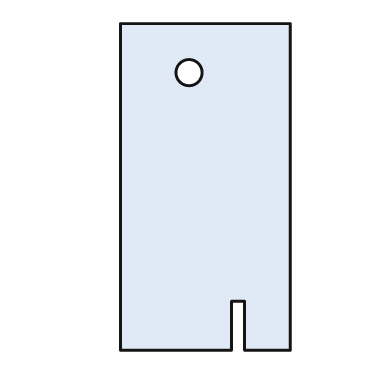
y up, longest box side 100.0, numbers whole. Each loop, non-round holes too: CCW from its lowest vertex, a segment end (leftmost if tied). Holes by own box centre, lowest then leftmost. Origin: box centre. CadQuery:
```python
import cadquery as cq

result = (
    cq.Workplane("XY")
    .moveTo(-26.0, -50.0)
    .lineTo(8.0, -50.0)
    .lineTo(8.0, -35.0)
    .lineTo(12.0, -35.0)
    .lineTo(12.0, -50.0)
    .lineTo(26.0, -50.0)
    .lineTo(26.0, 50.0)
    .lineTo(-26.0, 50.0)
    .close()
    .moveTo(-5.0, 35.0)
    .circle(4.0)
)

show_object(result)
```